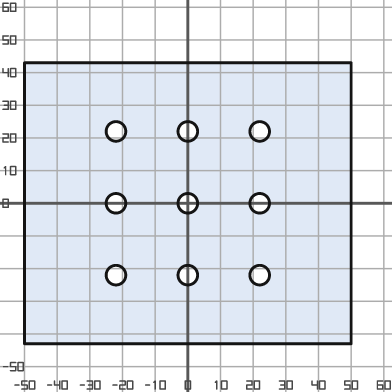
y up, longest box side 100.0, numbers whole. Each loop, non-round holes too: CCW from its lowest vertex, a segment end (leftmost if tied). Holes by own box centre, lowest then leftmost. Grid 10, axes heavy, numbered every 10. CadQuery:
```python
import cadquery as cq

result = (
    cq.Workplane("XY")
    .moveTo(-50.0, -43.0)
    .lineTo(50.0, -43.0)
    .lineTo(50.0, 43.0)
    .lineTo(-50.0, 43.0)
    .close()
    .moveTo(-22.0, -22.0)
    .circle(3.0)
    .moveTo(0.0, -22.0)
    .circle(3.0)
    .moveTo(22.0, -22.0)
    .circle(3.0)
    .moveTo(-22.0, 0.0)
    .circle(3.0)
    .moveTo(0.0, 0.0)
    .circle(3.0)
    .moveTo(22.0, 0.0)
    .circle(3.0)
    .moveTo(-22.0, 22.0)
    .circle(3.0)
    .moveTo(0.0, 22.0)
    .circle(3.0)
    .moveTo(22.0, 22.0)
    .circle(3.0)
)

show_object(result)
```